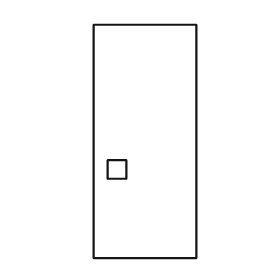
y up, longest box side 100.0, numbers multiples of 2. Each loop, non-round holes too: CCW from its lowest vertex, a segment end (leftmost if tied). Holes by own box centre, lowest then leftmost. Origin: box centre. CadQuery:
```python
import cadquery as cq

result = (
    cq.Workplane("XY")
    .moveTo(-22.0, -50.0)
    .lineTo(22.0, -50.0)
    .lineTo(22.0, 50.0)
    .lineTo(-22.0, 50.0)
    .close()
    .moveTo(-16.0, -16.0)
    .lineTo(-8.0, -16.0)
    .lineTo(-8.0, -8.0)
    .lineTo(-16.0, -8.0)
    .close()
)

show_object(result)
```